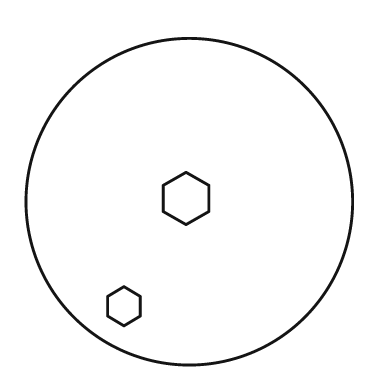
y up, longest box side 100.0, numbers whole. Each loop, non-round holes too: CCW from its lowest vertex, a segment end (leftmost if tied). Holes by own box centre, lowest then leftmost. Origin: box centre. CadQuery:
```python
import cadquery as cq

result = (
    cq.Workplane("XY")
    .moveTo(0.0, 0.0)
    .circle(50.0)
    .moveTo(-20.0, -38.0)
    .lineTo(-15.0, -35.0)
    .lineTo(-15.0, -29.0)
    .lineTo(-20.0, -26.0)
    .lineTo(-25.0, -29.0)
    .lineTo(-25.0, -35.0)
    .close()
    .moveTo(-1.0, -7.0)
    .lineTo(6.0, -3.0)
    .lineTo(6.0, 5.0)
    .lineTo(-1.0, 9.0)
    .lineTo(-8.0, 5.0)
    .lineTo(-8.0, -3.0)
    .close()
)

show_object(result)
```